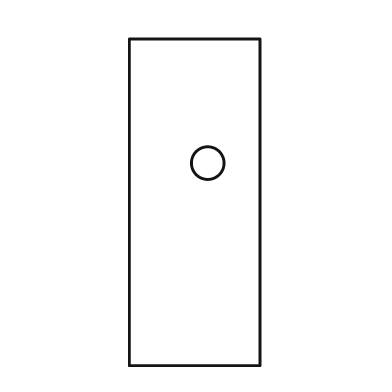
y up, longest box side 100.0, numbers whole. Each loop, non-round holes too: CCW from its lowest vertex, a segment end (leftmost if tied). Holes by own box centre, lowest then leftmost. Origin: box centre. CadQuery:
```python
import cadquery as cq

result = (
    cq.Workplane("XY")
    .moveTo(-20.0, -50.0)
    .lineTo(20.0, -50.0)
    .lineTo(20.0, 50.0)
    .lineTo(-20.0, 50.0)
    .close()
    .moveTo(4.0, 12.0)
    .circle(5.0)
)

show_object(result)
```